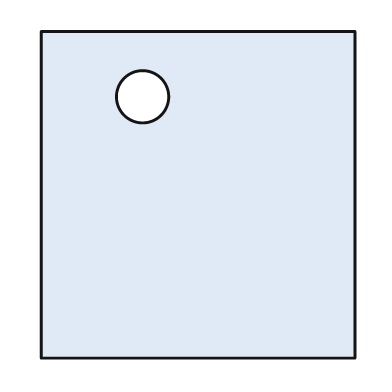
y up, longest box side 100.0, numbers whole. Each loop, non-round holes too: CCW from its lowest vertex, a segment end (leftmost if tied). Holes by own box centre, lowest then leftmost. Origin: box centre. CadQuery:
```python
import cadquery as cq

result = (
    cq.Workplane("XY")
    .moveTo(-48.0, -50.0)
    .lineTo(48.0, -50.0)
    .lineTo(48.0, 50.0)
    .lineTo(-48.0, 50.0)
    .close()
    .moveTo(-17.0, 30.0)
    .circle(8.0)
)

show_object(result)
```